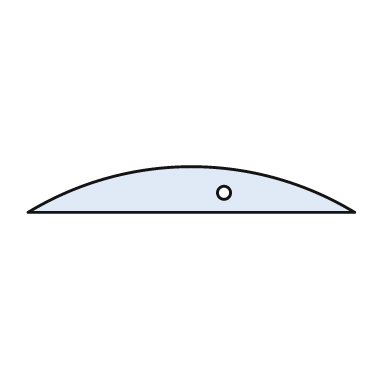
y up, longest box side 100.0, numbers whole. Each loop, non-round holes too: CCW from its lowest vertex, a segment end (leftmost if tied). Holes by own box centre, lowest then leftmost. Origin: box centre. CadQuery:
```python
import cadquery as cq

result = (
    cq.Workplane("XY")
    .moveTo(-50.0, -7.0)
    .lineTo(50.0, -7.0)
    .threePointArc((0.0, 7.0), (-50.0, -7.0))
    .close()
    .moveTo(10.0, -1.0)
    .circle(2.0)
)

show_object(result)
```